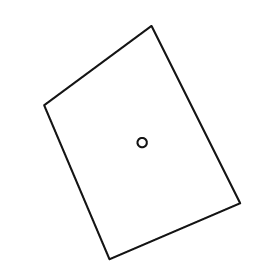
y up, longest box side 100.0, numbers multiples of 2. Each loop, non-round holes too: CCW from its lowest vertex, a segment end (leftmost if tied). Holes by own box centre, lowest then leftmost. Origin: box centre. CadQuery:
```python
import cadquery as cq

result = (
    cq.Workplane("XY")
    .moveTo(-14.0, -50.0)
    .lineTo(42.0, -26.0)
    .lineTo(4.0, 50.0)
    .lineTo(-42.0, 16.0)
    .close()
    .moveTo(0.0, 0.0)
    .circle(2.0)
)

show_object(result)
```